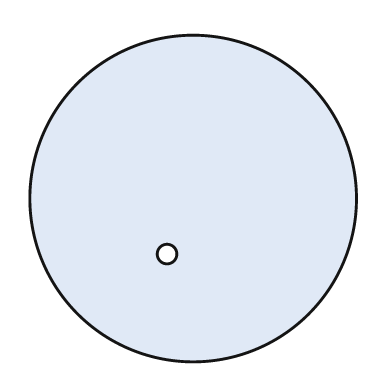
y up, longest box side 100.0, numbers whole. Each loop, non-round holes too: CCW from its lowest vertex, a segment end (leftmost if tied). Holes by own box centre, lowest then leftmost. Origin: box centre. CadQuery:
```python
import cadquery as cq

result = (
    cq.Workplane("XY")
    .moveTo(0.0, 0.0)
    .circle(50.0)
    .moveTo(-8.0, -17.0)
    .circle(3.0)
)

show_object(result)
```